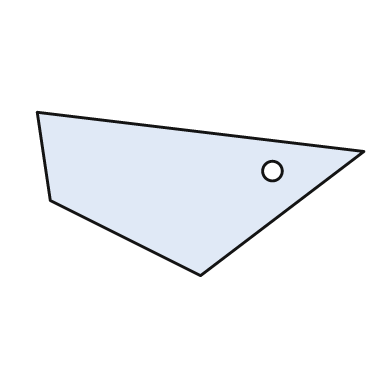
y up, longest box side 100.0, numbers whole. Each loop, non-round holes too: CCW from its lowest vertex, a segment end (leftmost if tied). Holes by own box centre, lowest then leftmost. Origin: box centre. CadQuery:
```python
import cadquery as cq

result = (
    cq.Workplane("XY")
    .moveTo(0.0, -25.0)
    .lineTo(50.0, 13.0)
    .lineTo(-50.0, 25.0)
    .lineTo(-46.0, -2.0)
    .close()
    .moveTo(22.0, 7.0)
    .circle(3.0)
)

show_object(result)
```